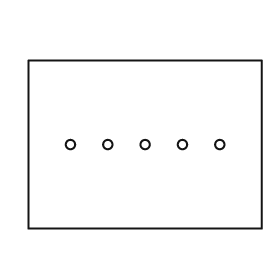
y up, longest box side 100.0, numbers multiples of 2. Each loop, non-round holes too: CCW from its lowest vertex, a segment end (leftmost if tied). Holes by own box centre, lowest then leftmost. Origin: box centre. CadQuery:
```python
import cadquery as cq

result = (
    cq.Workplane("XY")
    .moveTo(-50.0, -36.0)
    .lineTo(50.0, -36.0)
    .lineTo(50.0, 36.0)
    .lineTo(-50.0, 36.0)
    .close()
    .moveTo(-32.0, 0.0)
    .circle(2.0)
    .moveTo(-16.0, 0.0)
    .circle(2.0)
    .moveTo(0.0, 0.0)
    .circle(2.0)
    .moveTo(16.0, 0.0)
    .circle(2.0)
    .moveTo(32.0, 0.0)
    .circle(2.0)
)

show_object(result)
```